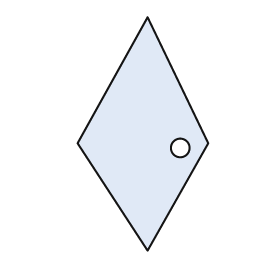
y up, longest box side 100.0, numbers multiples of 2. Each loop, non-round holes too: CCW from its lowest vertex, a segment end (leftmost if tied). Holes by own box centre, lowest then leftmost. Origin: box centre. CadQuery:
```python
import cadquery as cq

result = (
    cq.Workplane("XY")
    .moveTo(2.0, -50.0)
    .lineTo(28.0, -4.0)
    .lineTo(2.0, 50.0)
    .lineTo(-28.0, -4.0)
    .close()
    .moveTo(16.0, -6.0)
    .circle(4.0)
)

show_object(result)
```